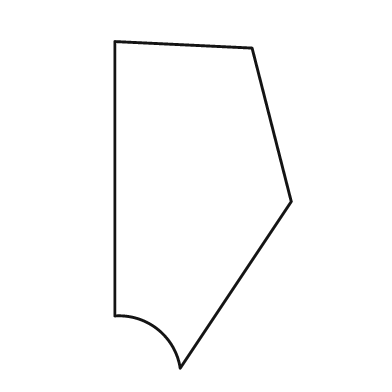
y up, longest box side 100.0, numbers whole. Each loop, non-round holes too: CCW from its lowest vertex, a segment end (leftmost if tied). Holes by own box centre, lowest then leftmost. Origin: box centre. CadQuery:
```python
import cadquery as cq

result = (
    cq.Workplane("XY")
    .moveTo(-7.0, -50.0)
    .lineTo(27.0, 1.0)
    .lineTo(15.0, 48.0)
    .lineTo(-27.0, 50.0)
    .lineTo(-27.0, -34.0)
    .threePointArc((-14.0, -38.0), (-7.0, -50.0))
    .close()
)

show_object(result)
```